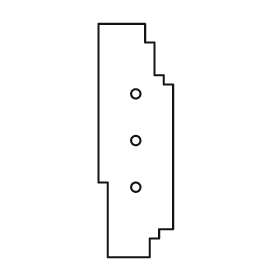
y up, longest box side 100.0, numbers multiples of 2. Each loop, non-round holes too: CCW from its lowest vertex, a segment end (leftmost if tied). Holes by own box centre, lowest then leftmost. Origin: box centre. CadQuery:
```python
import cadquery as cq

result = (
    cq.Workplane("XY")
    .moveTo(-12.0, -50.0)
    .lineTo(6.0, -50.0)
    .lineTo(6.0, -42.0)
    .lineTo(10.0, -42.0)
    .lineTo(10.0, -38.0)
    .lineTo(16.0, -38.0)
    .lineTo(16.0, 24.0)
    .lineTo(12.0, 24.0)
    .lineTo(12.0, 28.0)
    .lineTo(8.0, 28.0)
    .lineTo(8.0, 42.0)
    .lineTo(4.0, 42.0)
    .lineTo(4.0, 50.0)
    .lineTo(-16.0, 50.0)
    .lineTo(-16.0, -18.0)
    .lineTo(-12.0, -18.0)
    .close()
    .moveTo(0.0, -20.0)
    .circle(2.0)
    .moveTo(0.0, 0.0)
    .circle(2.0)
    .moveTo(0.0, 20.0)
    .circle(2.0)
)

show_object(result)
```